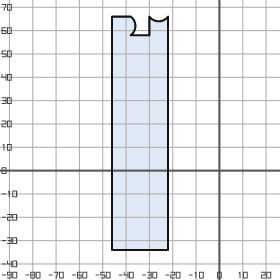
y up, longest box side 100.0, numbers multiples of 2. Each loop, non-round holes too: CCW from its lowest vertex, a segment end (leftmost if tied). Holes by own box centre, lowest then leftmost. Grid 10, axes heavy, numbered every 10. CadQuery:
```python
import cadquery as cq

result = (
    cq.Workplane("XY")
    .moveTo(-46.0, -34.0)
    .lineTo(-22.0, -34.0)
    .lineTo(-22.0, 66.0)
    .threePointArc((-26.0, 64.0), (-30.0, 66.0))
    .lineTo(-30.0, 58.0)
    .lineTo(-38.0, 58.0)
    .threePointArc((-36.0, 62.0), (-38.0, 66.0))
    .lineTo(-46.0, 66.0)
    .close()
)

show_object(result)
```